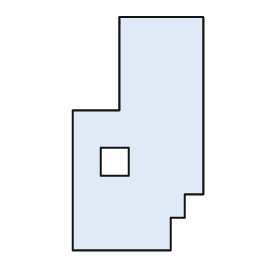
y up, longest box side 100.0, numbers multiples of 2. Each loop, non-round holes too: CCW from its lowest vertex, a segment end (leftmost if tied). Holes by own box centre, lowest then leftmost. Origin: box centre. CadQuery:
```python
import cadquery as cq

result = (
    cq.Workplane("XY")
    .moveTo(-28.0, -50.0)
    .lineTo(14.0, -50.0)
    .lineTo(14.0, -36.0)
    .lineTo(20.0, -36.0)
    .lineTo(20.0, -26.0)
    .lineTo(28.0, -26.0)
    .lineTo(28.0, 50.0)
    .lineTo(-8.0, 50.0)
    .lineTo(-8.0, 10.0)
    .lineTo(-28.0, 10.0)
    .close()
    .moveTo(-16.0, -18.0)
    .lineTo(-4.0, -18.0)
    .lineTo(-4.0, -6.0)
    .lineTo(-16.0, -6.0)
    .close()
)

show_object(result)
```